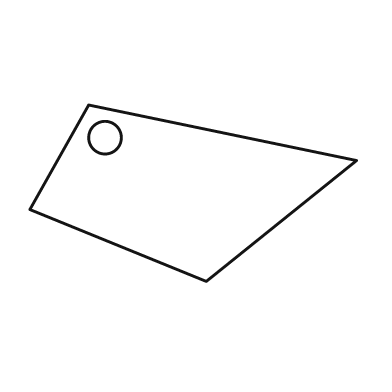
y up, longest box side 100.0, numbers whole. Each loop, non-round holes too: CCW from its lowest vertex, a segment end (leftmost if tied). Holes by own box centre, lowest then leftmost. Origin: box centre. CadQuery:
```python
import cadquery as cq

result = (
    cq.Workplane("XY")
    .moveTo(4.0, -27.0)
    .lineTo(50.0, 10.0)
    .lineTo(-32.0, 27.0)
    .lineTo(-50.0, -5.0)
    .close()
    .moveTo(-27.0, 17.0)
    .circle(5.0)
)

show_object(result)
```